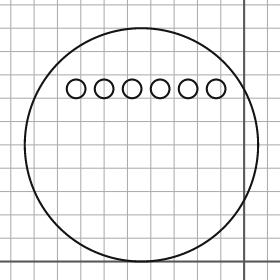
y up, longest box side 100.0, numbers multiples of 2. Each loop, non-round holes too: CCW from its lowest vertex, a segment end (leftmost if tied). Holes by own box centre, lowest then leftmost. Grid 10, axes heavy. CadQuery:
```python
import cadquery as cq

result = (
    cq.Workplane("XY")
    .moveTo(-44.0, 50.0)
    .circle(50.0)
    .moveTo(-72.0, 74.0)
    .circle(4.0)
    .moveTo(-60.0, 74.0)
    .circle(4.0)
    .moveTo(-48.0, 74.0)
    .circle(4.0)
    .moveTo(-36.0, 74.0)
    .circle(4.0)
    .moveTo(-24.0, 74.0)
    .circle(4.0)
    .moveTo(-12.0, 74.0)
    .circle(4.0)
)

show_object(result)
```